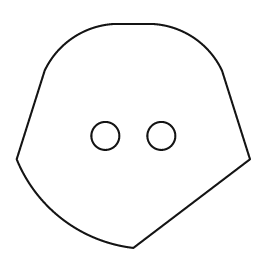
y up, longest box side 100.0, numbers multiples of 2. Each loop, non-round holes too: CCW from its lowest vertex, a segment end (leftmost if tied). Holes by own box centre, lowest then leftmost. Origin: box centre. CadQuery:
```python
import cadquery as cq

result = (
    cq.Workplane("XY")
    .moveTo(0.0, -48.0)
    .lineTo(50.0, -10.0)
    .lineTo(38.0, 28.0)
    .threePointArc((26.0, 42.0), (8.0, 48.0))
    .lineTo(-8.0, 48.0)
    .threePointArc((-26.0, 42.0), (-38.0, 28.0))
    .lineTo(-50.0, -10.0)
    .threePointArc((-30.0, -36.0), (0.0, -48.0))
    .close()
    .moveTo(-12.0, 0.0)
    .circle(6.0)
    .moveTo(12.0, 0.0)
    .circle(6.0)
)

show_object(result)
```